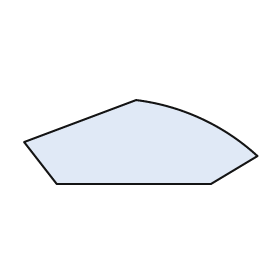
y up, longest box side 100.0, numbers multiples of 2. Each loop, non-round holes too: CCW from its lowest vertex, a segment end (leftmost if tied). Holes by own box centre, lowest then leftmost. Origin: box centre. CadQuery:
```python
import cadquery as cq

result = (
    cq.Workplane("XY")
    .moveTo(-36.0, -18.0)
    .lineTo(30.0, -18.0)
    .lineTo(50.0, -6.0)
    .threePointArc((26.0, 10.0), (-2.0, 18.0))
    .lineTo(-50.0, 0.0)
    .close()
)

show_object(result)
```